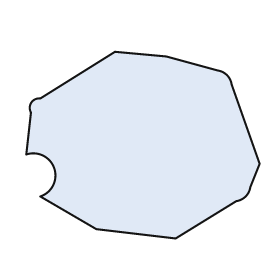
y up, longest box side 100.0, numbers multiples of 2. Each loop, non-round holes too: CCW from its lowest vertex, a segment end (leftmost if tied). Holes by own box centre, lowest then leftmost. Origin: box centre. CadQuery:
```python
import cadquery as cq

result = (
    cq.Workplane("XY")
    .moveTo(14.0, -40.0)
    .lineTo(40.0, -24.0)
    .threePointArc((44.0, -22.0), (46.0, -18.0))
    .lineTo(50.0, -8.0)
    .lineTo(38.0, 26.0)
    .threePointArc((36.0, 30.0), (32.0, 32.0))
    .lineTo(10.0, 38.0)
    .lineTo(-12.0, 40.0)
    .lineTo(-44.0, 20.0)
    .threePointArc((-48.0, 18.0), (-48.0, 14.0))
    .lineTo(-50.0, -4.0)
    .threePointArc((-38.0, -10.0), (-44.0, -22.0))
    .lineTo(-20.0, -36.0)
    .close()
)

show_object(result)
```